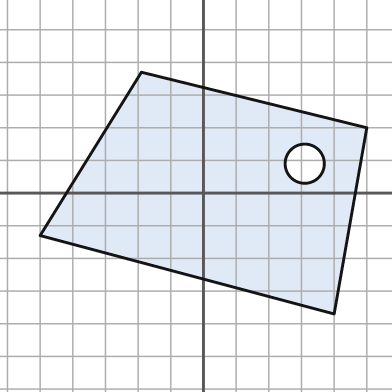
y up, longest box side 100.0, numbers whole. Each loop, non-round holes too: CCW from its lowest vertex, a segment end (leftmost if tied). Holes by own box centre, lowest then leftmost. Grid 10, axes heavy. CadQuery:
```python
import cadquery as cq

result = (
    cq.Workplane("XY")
    .moveTo(40.0, -37.0)
    .lineTo(50.0, 20.0)
    .lineTo(-19.0, 37.0)
    .lineTo(-50.0, -13.0)
    .close()
    .moveTo(31.0, 9.0)
    .circle(6.0)
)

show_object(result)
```